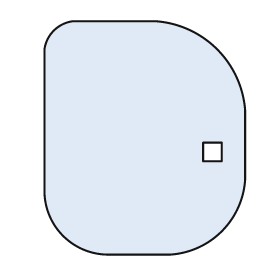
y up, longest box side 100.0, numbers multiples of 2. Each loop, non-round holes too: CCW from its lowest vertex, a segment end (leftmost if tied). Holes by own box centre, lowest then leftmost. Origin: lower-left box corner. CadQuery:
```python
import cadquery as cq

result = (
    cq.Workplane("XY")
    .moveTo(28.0, 0.0)
    .lineTo(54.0, 0.0)
    .threePointArc((76.0, 10.0), (86.0, 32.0))
    .lineTo(86.0, 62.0)
    .threePointArc((74.0, 88.0), (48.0, 100.0))
    .lineTo(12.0, 100.0)
    .threePointArc((4.0, 96.0), (0.0, 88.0))
    .lineTo(0.0, 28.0)
    .threePointArc((8.0, 8.0), (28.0, 0.0))
    .close()
    .moveTo(68.0, 40.0)
    .lineTo(76.0, 40.0)
    .lineTo(76.0, 48.0)
    .lineTo(68.0, 48.0)
    .close()
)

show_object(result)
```